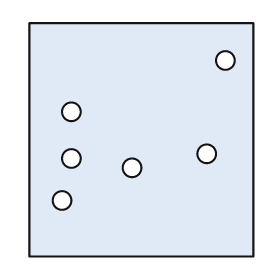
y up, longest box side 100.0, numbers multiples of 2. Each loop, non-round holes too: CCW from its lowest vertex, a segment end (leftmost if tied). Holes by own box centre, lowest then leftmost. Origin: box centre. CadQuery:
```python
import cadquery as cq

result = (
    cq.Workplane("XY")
    .moveTo(-48.0, -50.0)
    .lineTo(48.0, -50.0)
    .lineTo(48.0, 50.0)
    .lineTo(-48.0, 50.0)
    .close()
    .moveTo(-34.0, -26.0)
    .circle(4.0)
    .moveTo(-4.0, -12.0)
    .circle(4.0)
    .moveTo(-30.0, -8.0)
    .circle(4.0)
    .moveTo(28.0, -6.0)
    .circle(4.0)
    .moveTo(-30.0, 12.0)
    .circle(4.0)
    .moveTo(36.0, 34.0)
    .circle(4.0)
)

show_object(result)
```